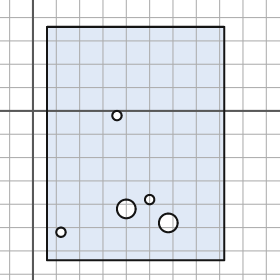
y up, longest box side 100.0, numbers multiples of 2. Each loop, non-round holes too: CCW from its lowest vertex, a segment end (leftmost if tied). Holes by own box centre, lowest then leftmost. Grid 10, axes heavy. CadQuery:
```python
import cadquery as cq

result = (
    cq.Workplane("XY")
    .moveTo(6.0, -64.0)
    .lineTo(82.0, -64.0)
    .lineTo(82.0, 36.0)
    .lineTo(6.0, 36.0)
    .close()
    .moveTo(12.0, -52.0)
    .circle(2.0)
    .moveTo(58.0, -48.0)
    .circle(4.0)
    .moveTo(40.0, -42.0)
    .circle(4.0)
    .moveTo(50.0, -38.0)
    .circle(2.0)
    .moveTo(36.0, -2.0)
    .circle(2.0)
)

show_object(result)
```